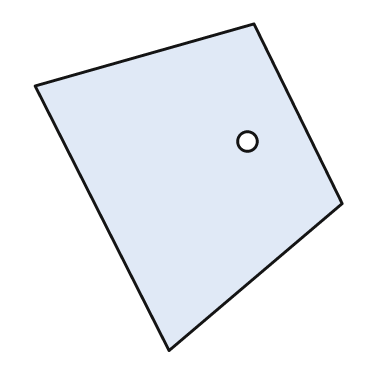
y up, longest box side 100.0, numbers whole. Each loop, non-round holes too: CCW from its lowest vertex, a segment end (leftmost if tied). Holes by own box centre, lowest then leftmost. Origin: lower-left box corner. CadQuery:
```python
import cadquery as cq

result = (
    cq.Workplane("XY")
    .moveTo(41.0, 0.0)
    .lineTo(94.0, 45.0)
    .lineTo(67.0, 100.0)
    .lineTo(0.0, 81.0)
    .close()
    .moveTo(65.0, 64.0)
    .circle(3.0)
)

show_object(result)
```